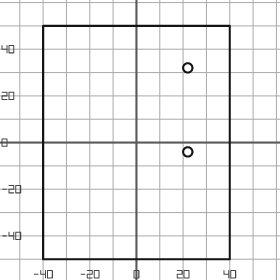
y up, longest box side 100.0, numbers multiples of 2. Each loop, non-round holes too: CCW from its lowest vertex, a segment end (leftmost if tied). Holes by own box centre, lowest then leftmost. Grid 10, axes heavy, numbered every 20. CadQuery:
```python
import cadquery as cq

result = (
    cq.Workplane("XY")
    .moveTo(-40.0, -50.0)
    .lineTo(40.0, -50.0)
    .lineTo(40.0, 50.0)
    .lineTo(-40.0, 50.0)
    .close()
    .moveTo(22.0, -4.0)
    .circle(2.0)
    .moveTo(22.0, 32.0)
    .circle(2.0)
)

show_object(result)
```